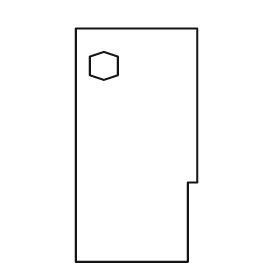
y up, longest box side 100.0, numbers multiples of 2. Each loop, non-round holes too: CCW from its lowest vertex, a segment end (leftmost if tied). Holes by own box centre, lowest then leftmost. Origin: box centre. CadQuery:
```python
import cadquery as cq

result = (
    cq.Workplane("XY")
    .moveTo(-26.0, -50.0)
    .lineTo(22.0, -50.0)
    .lineTo(22.0, -16.0)
    .lineTo(26.0, -16.0)
    .lineTo(26.0, 50.0)
    .lineTo(-26.0, 50.0)
    .close()
    .moveTo(-14.0, 28.0)
    .lineTo(-8.0, 30.0)
    .lineTo(-8.0, 38.0)
    .lineTo(-14.0, 40.0)
    .lineTo(-20.0, 38.0)
    .lineTo(-20.0, 30.0)
    .close()
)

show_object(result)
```